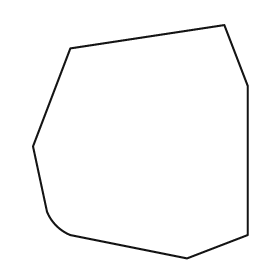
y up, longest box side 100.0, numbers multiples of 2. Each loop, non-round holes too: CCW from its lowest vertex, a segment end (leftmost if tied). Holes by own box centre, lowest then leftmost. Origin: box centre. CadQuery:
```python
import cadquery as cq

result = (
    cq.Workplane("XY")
    .moveTo(20.0, -50.0)
    .lineTo(46.0, -40.0)
    .lineTo(46.0, 24.0)
    .lineTo(36.0, 50.0)
    .lineTo(-30.0, 40.0)
    .lineTo(-46.0, -2.0)
    .lineTo(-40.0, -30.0)
    .threePointArc((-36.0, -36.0), (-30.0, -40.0))
    .close()
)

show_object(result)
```